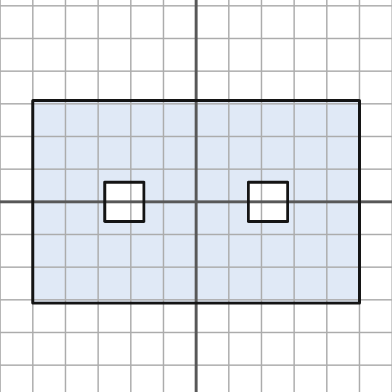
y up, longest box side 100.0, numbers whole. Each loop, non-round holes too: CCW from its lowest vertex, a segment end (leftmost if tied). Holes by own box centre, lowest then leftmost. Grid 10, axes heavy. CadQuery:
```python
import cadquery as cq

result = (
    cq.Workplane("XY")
    .moveTo(-50.0, -31.0)
    .lineTo(50.0, -31.0)
    .lineTo(50.0, 31.0)
    .lineTo(-50.0, 31.0)
    .close()
    .moveTo(-28.0, -6.0)
    .lineTo(-16.0, -6.0)
    .lineTo(-16.0, 6.0)
    .lineTo(-28.0, 6.0)
    .close()
    .moveTo(16.0, -6.0)
    .lineTo(28.0, -6.0)
    .lineTo(28.0, 6.0)
    .lineTo(16.0, 6.0)
    .close()
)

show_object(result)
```